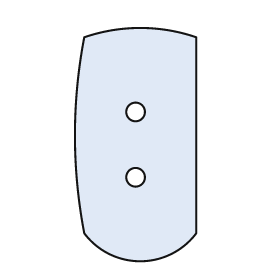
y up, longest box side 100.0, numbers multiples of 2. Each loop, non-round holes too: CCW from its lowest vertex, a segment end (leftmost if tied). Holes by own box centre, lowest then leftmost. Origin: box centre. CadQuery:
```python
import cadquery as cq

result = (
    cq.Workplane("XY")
    .moveTo(-22.0, -38.0)
    .threePointArc((2.0, -50.0), (26.0, -38.0))
    .lineTo(26.0, 46.0)
    .threePointArc((2.0, 50.0), (-22.0, 46.0))
    .threePointArc((-26.0, 4.0), (-22.0, -38.0))
    .close()
    .moveTo(0.0, -14.0)
    .circle(4.0)
    .moveTo(0.0, 14.0)
    .circle(4.0)
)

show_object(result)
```